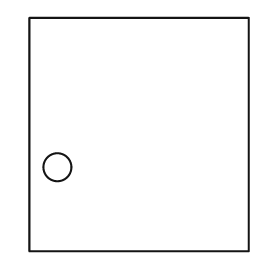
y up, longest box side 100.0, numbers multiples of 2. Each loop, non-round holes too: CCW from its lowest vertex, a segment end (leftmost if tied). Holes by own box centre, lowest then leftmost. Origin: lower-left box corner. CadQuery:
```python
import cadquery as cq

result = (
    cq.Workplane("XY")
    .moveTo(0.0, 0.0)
    .lineTo(94.0, 0.0)
    .lineTo(94.0, 100.0)
    .lineTo(0.0, 100.0)
    .close()
    .moveTo(12.0, 36.0)
    .circle(6.0)
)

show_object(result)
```